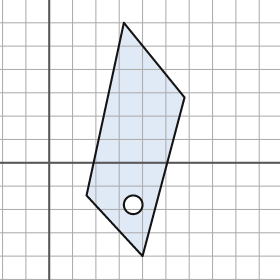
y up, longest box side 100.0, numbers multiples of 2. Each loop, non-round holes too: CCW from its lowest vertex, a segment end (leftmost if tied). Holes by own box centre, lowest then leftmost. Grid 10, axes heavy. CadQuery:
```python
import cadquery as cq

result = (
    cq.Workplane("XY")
    .moveTo(40.0, -40.0)
    .lineTo(58.0, 28.0)
    .lineTo(32.0, 60.0)
    .lineTo(16.0, -14.0)
    .close()
    .moveTo(36.0, -18.0)
    .circle(4.0)
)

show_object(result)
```